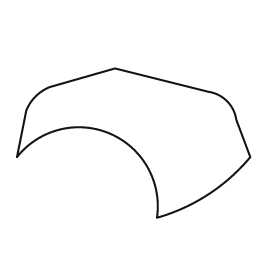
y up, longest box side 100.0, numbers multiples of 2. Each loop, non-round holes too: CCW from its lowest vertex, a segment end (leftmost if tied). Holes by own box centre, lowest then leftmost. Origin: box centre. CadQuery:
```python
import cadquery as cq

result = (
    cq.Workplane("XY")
    .moveTo(10.0, -32.0)
    .threePointArc((32.0, -22.0), (50.0, -6.0))
    .lineTo(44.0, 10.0)
    .threePointArc((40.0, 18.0), (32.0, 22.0))
    .lineTo(-8.0, 32.0)
    .lineTo(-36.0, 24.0)
    .threePointArc((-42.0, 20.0), (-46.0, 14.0))
    .lineTo(-50.0, -6.0)
    .threePointArc((-10.0, 4.0), (10.0, -32.0))
    .close()
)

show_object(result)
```